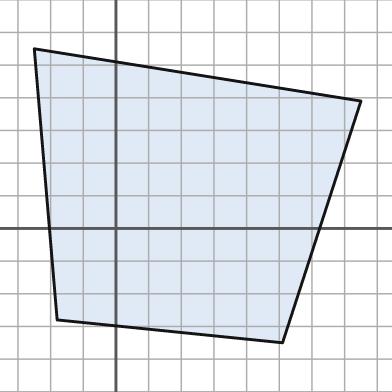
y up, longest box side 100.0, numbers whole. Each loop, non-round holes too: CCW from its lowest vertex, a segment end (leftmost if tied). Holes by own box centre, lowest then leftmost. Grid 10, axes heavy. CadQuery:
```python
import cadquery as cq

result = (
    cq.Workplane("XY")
    .moveTo(51.0, -35.0)
    .lineTo(75.0, 39.0)
    .lineTo(-25.0, 55.0)
    .lineTo(-18.0, -28.0)
    .close()
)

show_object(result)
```